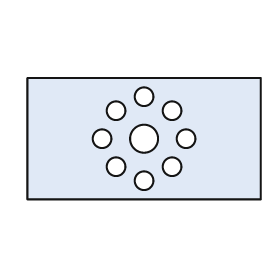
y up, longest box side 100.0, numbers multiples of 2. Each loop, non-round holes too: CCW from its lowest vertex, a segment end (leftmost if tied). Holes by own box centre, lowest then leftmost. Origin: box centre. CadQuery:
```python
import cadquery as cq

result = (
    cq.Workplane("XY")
    .moveTo(-50.0, -26.0)
    .lineTo(50.0, -26.0)
    .lineTo(50.0, 26.0)
    .lineTo(-50.0, 26.0)
    .close()
    .moveTo(0.0, -18.0)
    .circle(4.0)
    .moveTo(-12.0, -12.0)
    .circle(4.0)
    .moveTo(12.0, -12.0)
    .circle(4.0)
    .moveTo(-18.0, 0.0)
    .circle(4.0)
    .moveTo(0.0, 0.0)
    .circle(6.0)
    .moveTo(18.0, 0.0)
    .circle(4.0)
    .moveTo(-12.0, 12.0)
    .circle(4.0)
    .moveTo(12.0, 12.0)
    .circle(4.0)
    .moveTo(0.0, 18.0)
    .circle(4.0)
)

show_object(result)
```